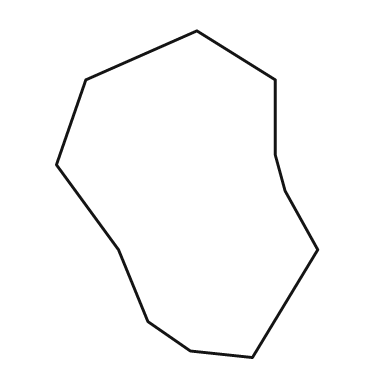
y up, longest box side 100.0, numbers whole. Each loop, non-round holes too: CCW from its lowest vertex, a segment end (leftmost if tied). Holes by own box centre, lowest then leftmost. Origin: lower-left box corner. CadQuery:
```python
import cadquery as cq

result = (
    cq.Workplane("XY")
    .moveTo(60.0, 0.0)
    .lineTo(80.0, 33.0)
    .lineTo(70.0, 51.0)
    .lineTo(67.0, 62.0)
    .lineTo(67.0, 85.0)
    .lineTo(43.0, 100.0)
    .lineTo(9.0, 85.0)
    .lineTo(0.0, 59.0)
    .lineTo(19.0, 33.0)
    .lineTo(28.0, 11.0)
    .lineTo(41.0, 2.0)
    .close()
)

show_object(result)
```